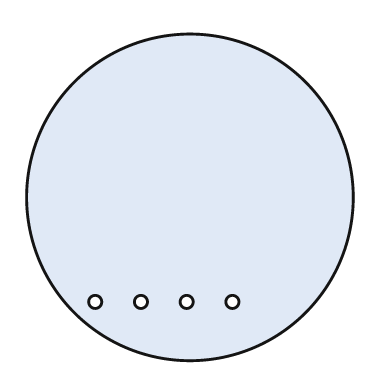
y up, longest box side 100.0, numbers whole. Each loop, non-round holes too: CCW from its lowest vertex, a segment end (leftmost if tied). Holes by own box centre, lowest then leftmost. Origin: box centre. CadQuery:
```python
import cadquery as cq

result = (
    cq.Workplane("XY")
    .moveTo(0.0, 0.0)
    .circle(50.0)
    .moveTo(-29.0, -32.0)
    .circle(2.0)
    .moveTo(-15.0, -32.0)
    .circle(2.0)
    .moveTo(-1.0, -32.0)
    .circle(2.0)
    .moveTo(13.0, -32.0)
    .circle(2.0)
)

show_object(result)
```